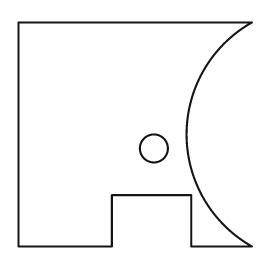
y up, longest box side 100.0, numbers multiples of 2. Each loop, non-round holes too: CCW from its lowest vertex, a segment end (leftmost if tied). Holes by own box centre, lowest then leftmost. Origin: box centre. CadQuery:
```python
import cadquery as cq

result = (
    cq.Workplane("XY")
    .moveTo(-50.0, -48.0)
    .lineTo(-10.0, -48.0)
    .lineTo(-10.0, -26.0)
    .lineTo(24.0, -26.0)
    .lineTo(24.0, -48.0)
    .lineTo(50.0, -48.0)
    .threePointArc((22.0, 0.0), (50.0, 48.0))
    .lineTo(-50.0, 48.0)
    .close()
    .moveTo(8.0, -6.0)
    .circle(6.0)
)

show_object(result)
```